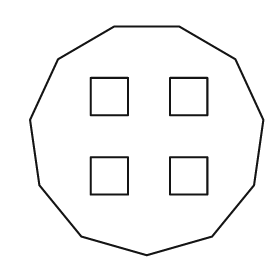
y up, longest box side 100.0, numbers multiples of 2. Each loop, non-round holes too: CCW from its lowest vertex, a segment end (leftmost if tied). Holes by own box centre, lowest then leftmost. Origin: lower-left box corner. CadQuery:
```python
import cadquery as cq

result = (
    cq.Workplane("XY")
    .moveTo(50.0, 0.0)
    .lineTo(78.0, 8.0)
    .lineTo(96.0, 30.0)
    .lineTo(100.0, 58.0)
    .lineTo(88.0, 84.0)
    .lineTo(64.0, 98.0)
    .lineTo(36.0, 98.0)
    .lineTo(12.0, 84.0)
    .lineTo(0.0, 58.0)
    .lineTo(4.0, 30.0)
    .lineTo(22.0, 8.0)
    .close()
    .moveTo(26.0, 26.0)
    .lineTo(42.0, 26.0)
    .lineTo(42.0, 42.0)
    .lineTo(26.0, 42.0)
    .close()
    .moveTo(60.0, 26.0)
    .lineTo(76.0, 26.0)
    .lineTo(76.0, 42.0)
    .lineTo(60.0, 42.0)
    .close()
    .moveTo(26.0, 60.0)
    .lineTo(42.0, 60.0)
    .lineTo(42.0, 76.0)
    .lineTo(26.0, 76.0)
    .close()
    .moveTo(60.0, 60.0)
    .lineTo(76.0, 60.0)
    .lineTo(76.0, 76.0)
    .lineTo(60.0, 76.0)
    .close()
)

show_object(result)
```